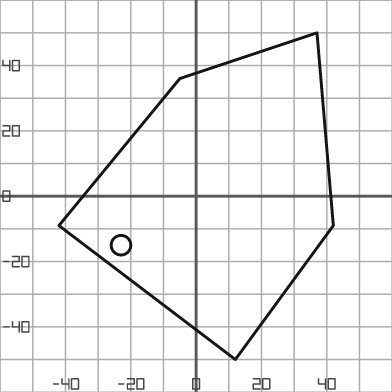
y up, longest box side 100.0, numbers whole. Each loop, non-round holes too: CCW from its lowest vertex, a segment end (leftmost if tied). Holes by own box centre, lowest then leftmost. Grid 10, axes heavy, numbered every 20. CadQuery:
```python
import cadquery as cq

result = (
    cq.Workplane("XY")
    .moveTo(12.0, -50.0)
    .lineTo(42.0, -9.0)
    .lineTo(37.0, 50.0)
    .lineTo(-5.0, 36.0)
    .lineTo(-42.0, -9.0)
    .close()
    .moveTo(-23.0, -15.0)
    .circle(3.0)
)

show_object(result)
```